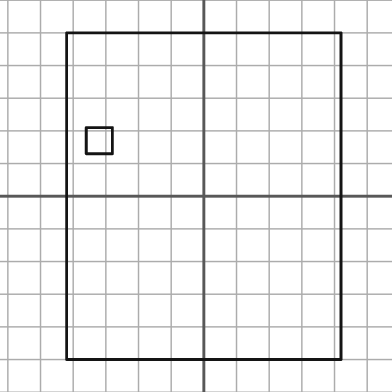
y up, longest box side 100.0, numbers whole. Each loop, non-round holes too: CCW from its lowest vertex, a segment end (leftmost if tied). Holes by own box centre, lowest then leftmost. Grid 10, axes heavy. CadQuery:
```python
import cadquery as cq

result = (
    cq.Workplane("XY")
    .moveTo(-42.0, -50.0)
    .lineTo(42.0, -50.0)
    .lineTo(42.0, 50.0)
    .lineTo(-42.0, 50.0)
    .close()
    .moveTo(-36.0, 13.0)
    .lineTo(-28.0, 13.0)
    .lineTo(-28.0, 21.0)
    .lineTo(-36.0, 21.0)
    .close()
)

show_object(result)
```